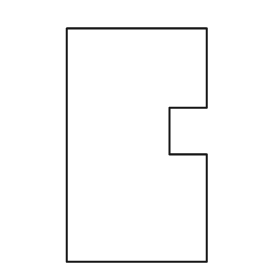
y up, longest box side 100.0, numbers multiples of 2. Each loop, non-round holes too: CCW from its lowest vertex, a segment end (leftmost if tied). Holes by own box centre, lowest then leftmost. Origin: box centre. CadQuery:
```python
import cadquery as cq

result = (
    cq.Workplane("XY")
    .moveTo(-30.0, -50.0)
    .lineTo(30.0, -50.0)
    .lineTo(30.0, -4.0)
    .lineTo(14.0, -4.0)
    .lineTo(14.0, 16.0)
    .lineTo(30.0, 16.0)
    .lineTo(30.0, 50.0)
    .lineTo(-30.0, 50.0)
    .close()
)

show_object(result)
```